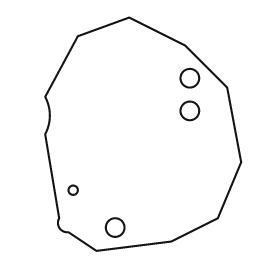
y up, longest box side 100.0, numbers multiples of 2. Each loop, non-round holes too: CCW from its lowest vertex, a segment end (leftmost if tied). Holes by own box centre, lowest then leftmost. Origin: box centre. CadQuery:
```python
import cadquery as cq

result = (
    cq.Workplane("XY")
    .moveTo(-20.0, -50.0)
    .lineTo(12.0, -46.0)
    .lineTo(32.0, -36.0)
    .lineTo(42.0, -12.0)
    .lineTo(36.0, 20.0)
    .lineTo(18.0, 38.0)
    .lineTo(-6.0, 50.0)
    .lineTo(-28.0, 42.0)
    .lineTo(-42.0, 16.0)
    .threePointArc((-40.0, 8.0), (-42.0, 0.0))
    .lineTo(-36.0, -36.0)
    .threePointArc((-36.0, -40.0), (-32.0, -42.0))
    .close()
    .moveTo(-12.0, -40.0)
    .circle(4.0)
    .moveTo(-30.0, -24.0)
    .circle(2.0)
    .moveTo(20.0, 10.0)
    .circle(4.0)
    .moveTo(20.0, 24.0)
    .circle(4.0)
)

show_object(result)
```